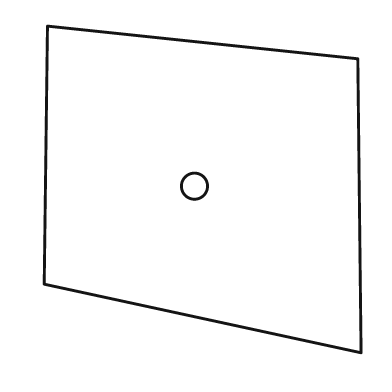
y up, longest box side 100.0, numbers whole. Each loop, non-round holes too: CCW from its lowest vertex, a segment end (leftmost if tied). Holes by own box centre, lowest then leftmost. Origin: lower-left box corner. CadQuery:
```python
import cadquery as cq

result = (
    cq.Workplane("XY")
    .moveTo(97.0, 0.0)
    .lineTo(96.0, 90.0)
    .lineTo(1.0, 100.0)
    .lineTo(0.0, 21.0)
    .close()
    .moveTo(46.0, 51.0)
    .circle(4.0)
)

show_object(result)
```